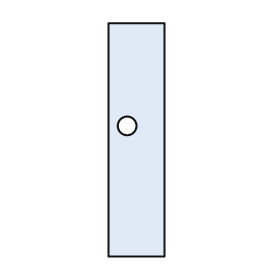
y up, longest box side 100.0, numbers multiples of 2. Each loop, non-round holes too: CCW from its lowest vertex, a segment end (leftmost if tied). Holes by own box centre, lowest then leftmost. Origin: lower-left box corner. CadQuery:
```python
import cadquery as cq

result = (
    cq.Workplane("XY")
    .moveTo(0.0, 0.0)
    .lineTo(24.0, 0.0)
    .lineTo(24.0, 100.0)
    .lineTo(0.0, 100.0)
    .close()
    .moveTo(8.0, 56.0)
    .circle(4.0)
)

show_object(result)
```